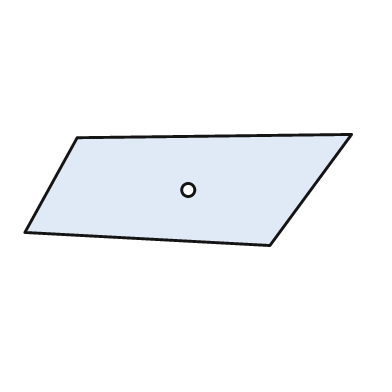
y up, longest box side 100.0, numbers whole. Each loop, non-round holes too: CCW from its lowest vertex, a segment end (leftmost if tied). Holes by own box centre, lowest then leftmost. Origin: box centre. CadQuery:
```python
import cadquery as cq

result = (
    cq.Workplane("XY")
    .moveTo(25.0, -17.0)
    .lineTo(50.0, 17.0)
    .lineTo(-34.0, 16.0)
    .lineTo(-50.0, -13.0)
    .close()
    .moveTo(0.0, 0.0)
    .circle(2.0)
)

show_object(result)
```